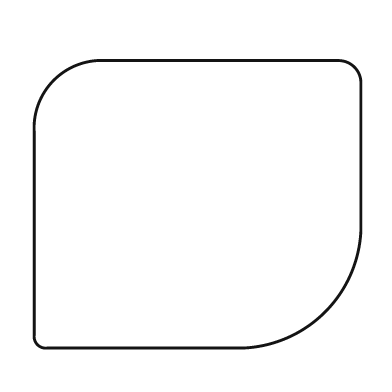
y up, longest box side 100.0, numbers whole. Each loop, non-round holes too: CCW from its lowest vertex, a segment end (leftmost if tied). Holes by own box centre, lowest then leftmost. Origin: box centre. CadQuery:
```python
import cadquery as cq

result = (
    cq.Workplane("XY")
    .moveTo(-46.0, -44.0)
    .lineTo(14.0, -44.0)
    .threePointArc((39.0, -33.0), (50.0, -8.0))
    .lineTo(50.0, 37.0)
    .threePointArc((48.0, 42.0), (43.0, 44.0))
    .lineTo(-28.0, 44.0)
    .threePointArc((-44.0, 38.0), (-50.0, 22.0))
    .lineTo(-50.0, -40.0)
    .threePointArc((-49.0, -43.0), (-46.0, -44.0))
    .close()
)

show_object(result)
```